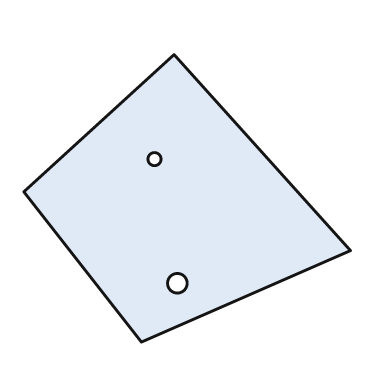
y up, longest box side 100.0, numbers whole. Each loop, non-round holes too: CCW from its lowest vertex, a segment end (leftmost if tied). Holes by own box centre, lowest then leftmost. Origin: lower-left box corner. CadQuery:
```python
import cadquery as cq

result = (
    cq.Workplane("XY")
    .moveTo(36.0, 0.0)
    .lineTo(100.0, 28.0)
    .lineTo(46.0, 88.0)
    .lineTo(0.0, 46.0)
    .close()
    .moveTo(47.0, 18.0)
    .circle(3.0)
    .moveTo(40.0, 56.0)
    .circle(2.0)
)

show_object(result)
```